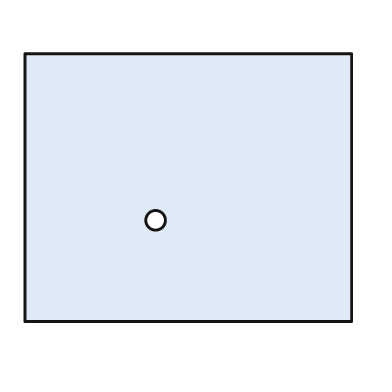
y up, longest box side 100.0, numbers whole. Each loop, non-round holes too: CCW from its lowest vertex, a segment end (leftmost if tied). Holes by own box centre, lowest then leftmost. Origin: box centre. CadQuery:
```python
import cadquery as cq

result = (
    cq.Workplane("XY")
    .moveTo(-50.0, -41.0)
    .lineTo(50.0, -41.0)
    .lineTo(50.0, 41.0)
    .lineTo(-50.0, 41.0)
    .close()
    .moveTo(-10.0, -10.0)
    .circle(3.0)
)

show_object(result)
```